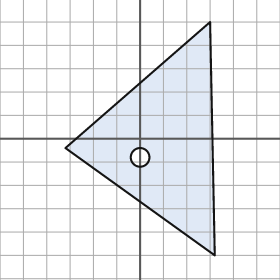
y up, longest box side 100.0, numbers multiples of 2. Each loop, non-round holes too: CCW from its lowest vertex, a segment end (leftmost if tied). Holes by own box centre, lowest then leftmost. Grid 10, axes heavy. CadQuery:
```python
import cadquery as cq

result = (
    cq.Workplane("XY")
    .moveTo(32.0, -50.0)
    .lineTo(30.0, 50.0)
    .lineTo(-32.0, -4.0)
    .close()
    .moveTo(0.0, -8.0)
    .circle(4.0)
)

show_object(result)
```